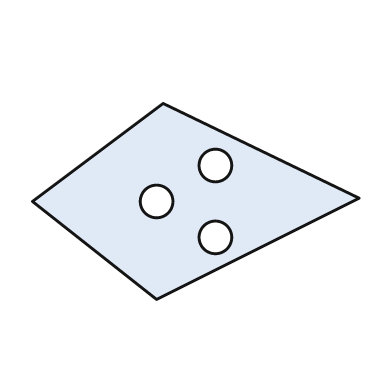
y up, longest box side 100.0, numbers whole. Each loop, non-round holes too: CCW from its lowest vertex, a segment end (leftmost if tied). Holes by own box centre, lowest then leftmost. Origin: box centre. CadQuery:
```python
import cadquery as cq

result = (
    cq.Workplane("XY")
    .moveTo(-12.0, -30.0)
    .lineTo(50.0, 1.0)
    .lineTo(-10.0, 30.0)
    .lineTo(-50.0, 0.0)
    .close()
    .moveTo(6.0, -11.0)
    .circle(5.0)
    .moveTo(-12.0, 0.0)
    .circle(5.0)
    .moveTo(6.0, 11.0)
    .circle(5.0)
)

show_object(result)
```